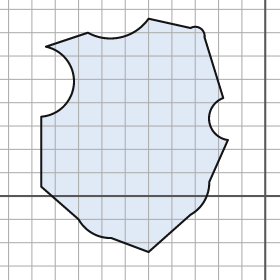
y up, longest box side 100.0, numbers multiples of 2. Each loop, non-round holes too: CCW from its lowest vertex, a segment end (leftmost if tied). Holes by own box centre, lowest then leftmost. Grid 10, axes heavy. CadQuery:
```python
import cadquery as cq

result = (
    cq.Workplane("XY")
    .moveTo(-50.0, -24.0)
    .lineTo(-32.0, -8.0)
    .threePointArc((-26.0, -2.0), (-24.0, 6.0))
    .lineTo(-16.0, 24.0)
    .threePointArc((-24.0, 32.0), (-18.0, 42.0))
    .lineTo(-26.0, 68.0)
    .threePointArc((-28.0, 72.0), (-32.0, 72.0))
    .lineTo(-50.0, 76.0)
    .threePointArc((-62.0, 68.0), (-76.0, 70.0))
    .lineTo(-94.0, 64.0)
    .threePointArc((-82.0, 48.0), (-96.0, 34.0))
    .lineTo(-96.0, 4.0)
    .lineTo(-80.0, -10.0)
    .threePointArc((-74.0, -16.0), (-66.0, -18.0))
    .close()
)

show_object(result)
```